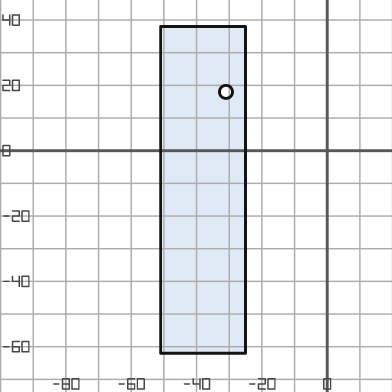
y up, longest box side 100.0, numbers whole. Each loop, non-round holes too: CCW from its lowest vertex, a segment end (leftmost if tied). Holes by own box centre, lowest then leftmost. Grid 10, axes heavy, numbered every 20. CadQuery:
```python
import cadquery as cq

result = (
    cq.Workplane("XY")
    .moveTo(-51.0, -62.0)
    .lineTo(-25.0, -62.0)
    .lineTo(-25.0, 38.0)
    .lineTo(-51.0, 38.0)
    .close()
    .moveTo(-31.0, 18.0)
    .circle(2.0)
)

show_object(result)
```